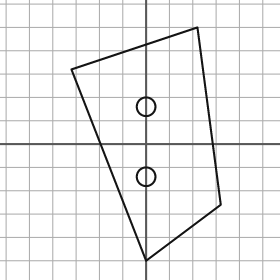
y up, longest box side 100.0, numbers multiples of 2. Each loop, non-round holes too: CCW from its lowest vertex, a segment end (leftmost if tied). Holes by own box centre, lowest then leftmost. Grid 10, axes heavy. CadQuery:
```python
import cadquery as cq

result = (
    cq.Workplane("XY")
    .moveTo(0.0, -50.0)
    .lineTo(32.0, -26.0)
    .lineTo(22.0, 50.0)
    .lineTo(-32.0, 32.0)
    .close()
    .moveTo(0.0, -14.0)
    .circle(4.0)
    .moveTo(0.0, 16.0)
    .circle(4.0)
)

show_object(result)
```